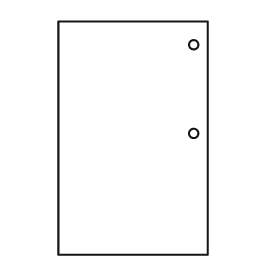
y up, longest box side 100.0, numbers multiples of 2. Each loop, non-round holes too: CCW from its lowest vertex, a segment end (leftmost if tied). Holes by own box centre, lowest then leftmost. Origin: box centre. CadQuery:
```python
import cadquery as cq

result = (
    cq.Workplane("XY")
    .moveTo(-32.0, -50.0)
    .lineTo(32.0, -50.0)
    .lineTo(32.0, 50.0)
    .lineTo(-32.0, 50.0)
    .close()
    .moveTo(26.0, 2.0)
    .circle(2.0)
    .moveTo(26.0, 40.0)
    .circle(2.0)
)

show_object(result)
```